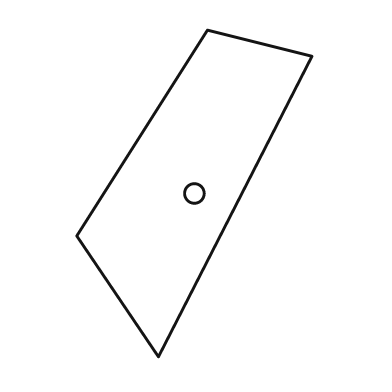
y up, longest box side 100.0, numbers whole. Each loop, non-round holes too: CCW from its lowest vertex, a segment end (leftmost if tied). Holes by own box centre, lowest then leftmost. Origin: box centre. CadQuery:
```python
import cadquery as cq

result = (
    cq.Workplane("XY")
    .moveTo(-11.0, -50.0)
    .lineTo(36.0, 42.0)
    .lineTo(4.0, 50.0)
    .lineTo(-36.0, -13.0)
    .close()
    .moveTo(0.0, 0.0)
    .circle(3.0)
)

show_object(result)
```